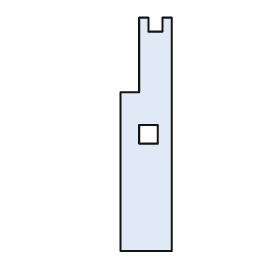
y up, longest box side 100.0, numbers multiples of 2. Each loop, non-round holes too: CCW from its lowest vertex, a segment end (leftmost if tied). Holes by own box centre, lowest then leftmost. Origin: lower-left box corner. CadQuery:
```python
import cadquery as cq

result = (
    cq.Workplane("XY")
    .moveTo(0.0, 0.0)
    .lineTo(22.0, 0.0)
    .lineTo(22.0, 100.0)
    .lineTo(18.0, 100.0)
    .lineTo(18.0, 94.0)
    .lineTo(12.0, 94.0)
    .lineTo(12.0, 100.0)
    .lineTo(8.0, 100.0)
    .lineTo(8.0, 68.0)
    .lineTo(0.0, 68.0)
    .close()
    .moveTo(8.0, 46.0)
    .lineTo(16.0, 46.0)
    .lineTo(16.0, 54.0)
    .lineTo(8.0, 54.0)
    .close()
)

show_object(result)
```